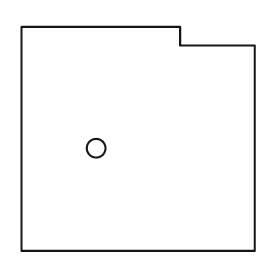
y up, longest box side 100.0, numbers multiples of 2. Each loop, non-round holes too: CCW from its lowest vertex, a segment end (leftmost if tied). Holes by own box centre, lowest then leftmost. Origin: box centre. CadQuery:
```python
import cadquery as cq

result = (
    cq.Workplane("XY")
    .moveTo(-50.0, -48.0)
    .lineTo(50.0, -48.0)
    .lineTo(50.0, 40.0)
    .lineTo(18.0, 40.0)
    .lineTo(18.0, 48.0)
    .lineTo(-50.0, 48.0)
    .close()
    .moveTo(-18.0, -4.0)
    .circle(4.0)
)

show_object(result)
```